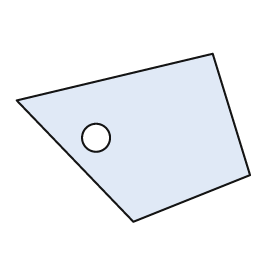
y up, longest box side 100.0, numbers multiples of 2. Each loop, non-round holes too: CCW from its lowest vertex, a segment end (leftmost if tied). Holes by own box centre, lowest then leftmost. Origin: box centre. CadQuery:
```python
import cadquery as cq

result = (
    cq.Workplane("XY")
    .moveTo(0.0, -36.0)
    .lineTo(50.0, -16.0)
    .lineTo(34.0, 36.0)
    .lineTo(-50.0, 16.0)
    .close()
    .moveTo(-16.0, 0.0)
    .circle(6.0)
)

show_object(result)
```